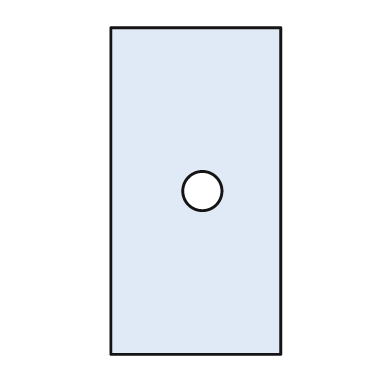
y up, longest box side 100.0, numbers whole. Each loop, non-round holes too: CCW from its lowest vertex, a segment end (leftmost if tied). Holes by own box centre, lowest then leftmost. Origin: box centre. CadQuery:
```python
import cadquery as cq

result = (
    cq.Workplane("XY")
    .moveTo(-26.0, -50.0)
    .lineTo(26.0, -50.0)
    .lineTo(26.0, 50.0)
    .lineTo(-26.0, 50.0)
    .close()
    .moveTo(2.0, 0.0)
    .circle(6.0)
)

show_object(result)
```